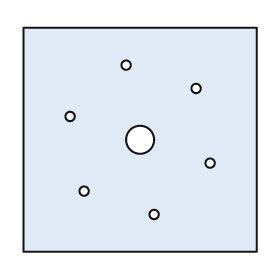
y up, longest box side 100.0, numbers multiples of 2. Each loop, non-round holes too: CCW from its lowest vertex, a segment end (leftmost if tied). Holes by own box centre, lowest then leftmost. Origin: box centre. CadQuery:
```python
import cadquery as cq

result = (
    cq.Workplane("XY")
    .moveTo(-50.0, -48.0)
    .lineTo(50.0, -48.0)
    .lineTo(50.0, 48.0)
    .lineTo(-50.0, 48.0)
    .close()
    .moveTo(6.0, -32.0)
    .circle(2.0)
    .moveTo(-24.0, -22.0)
    .circle(2.0)
    .moveTo(30.0, -10.0)
    .circle(2.0)
    .moveTo(0.0, 0.0)
    .circle(6.0)
    .moveTo(-30.0, 10.0)
    .circle(2.0)
    .moveTo(24.0, 22.0)
    .circle(2.0)
    .moveTo(-6.0, 32.0)
    .circle(2.0)
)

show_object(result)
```